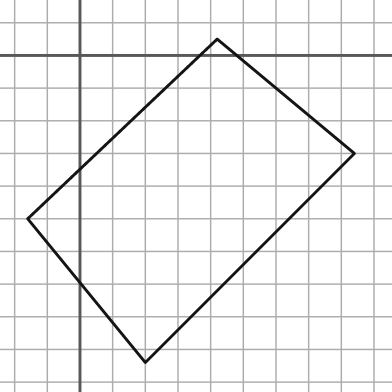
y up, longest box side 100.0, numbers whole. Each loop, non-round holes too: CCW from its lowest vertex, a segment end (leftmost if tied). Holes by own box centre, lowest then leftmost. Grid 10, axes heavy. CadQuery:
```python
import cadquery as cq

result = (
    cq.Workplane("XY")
    .moveTo(20.0, -94.0)
    .lineTo(84.0, -30.0)
    .lineTo(42.0, 5.0)
    .lineTo(-16.0, -50.0)
    .close()
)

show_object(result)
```